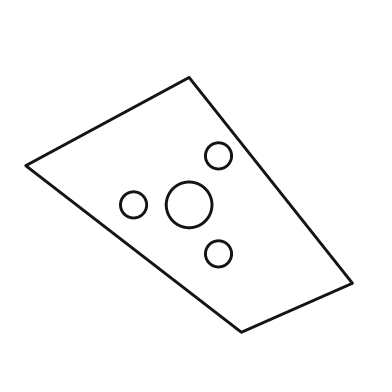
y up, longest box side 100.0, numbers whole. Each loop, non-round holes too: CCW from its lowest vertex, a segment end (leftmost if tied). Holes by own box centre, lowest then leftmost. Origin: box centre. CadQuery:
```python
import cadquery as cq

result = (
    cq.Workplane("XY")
    .moveTo(16.0, -39.0)
    .lineTo(50.0, -24.0)
    .lineTo(0.0, 39.0)
    .lineTo(-50.0, 12.0)
    .close()
    .moveTo(9.0, -15.0)
    .circle(4.0)
    .moveTo(-17.0, 0.0)
    .circle(4.0)
    .moveTo(0.0, 0.0)
    .circle(7.0)
    .moveTo(9.0, 15.0)
    .circle(4.0)
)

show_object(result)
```